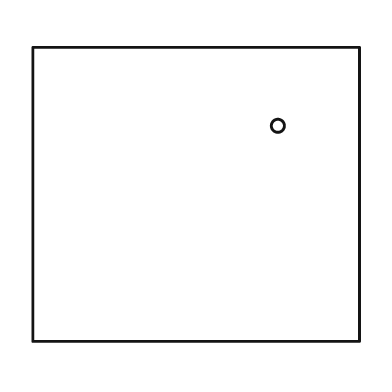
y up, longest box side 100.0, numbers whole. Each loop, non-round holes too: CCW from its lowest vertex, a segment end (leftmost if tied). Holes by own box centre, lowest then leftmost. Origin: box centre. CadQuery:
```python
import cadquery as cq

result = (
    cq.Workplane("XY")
    .moveTo(-50.0, -45.0)
    .lineTo(50.0, -45.0)
    .lineTo(50.0, 45.0)
    .lineTo(-50.0, 45.0)
    .close()
    .moveTo(25.0, 21.0)
    .circle(2.0)
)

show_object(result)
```